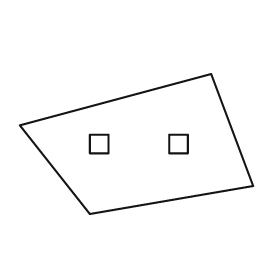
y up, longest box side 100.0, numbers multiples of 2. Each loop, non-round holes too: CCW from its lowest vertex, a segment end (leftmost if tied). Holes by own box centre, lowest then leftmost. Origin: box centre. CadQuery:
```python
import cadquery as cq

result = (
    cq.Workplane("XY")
    .moveTo(-20.0, -30.0)
    .lineTo(50.0, -18.0)
    .lineTo(32.0, 30.0)
    .lineTo(-50.0, 8.0)
    .close()
    .moveTo(-20.0, -4.0)
    .lineTo(-12.0, -4.0)
    .lineTo(-12.0, 4.0)
    .lineTo(-20.0, 4.0)
    .close()
    .moveTo(14.0, -4.0)
    .lineTo(22.0, -4.0)
    .lineTo(22.0, 4.0)
    .lineTo(14.0, 4.0)
    .close()
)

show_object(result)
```